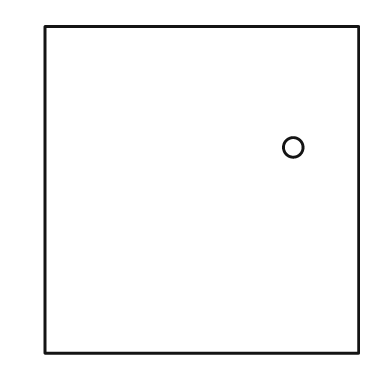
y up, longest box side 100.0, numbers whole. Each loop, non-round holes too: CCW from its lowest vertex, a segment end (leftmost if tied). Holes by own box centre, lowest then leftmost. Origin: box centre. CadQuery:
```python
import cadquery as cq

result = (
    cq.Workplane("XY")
    .moveTo(-48.0, -50.0)
    .lineTo(48.0, -50.0)
    .lineTo(48.0, 50.0)
    .lineTo(-48.0, 50.0)
    .close()
    .moveTo(28.0, 13.0)
    .circle(3.0)
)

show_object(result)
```